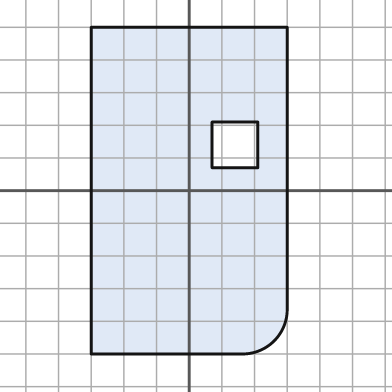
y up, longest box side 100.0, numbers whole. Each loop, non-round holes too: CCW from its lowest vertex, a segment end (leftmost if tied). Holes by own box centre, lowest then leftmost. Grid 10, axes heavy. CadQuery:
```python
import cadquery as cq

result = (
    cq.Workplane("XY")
    .moveTo(-30.0, -50.0)
    .lineTo(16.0, -50.0)
    .threePointArc((26.0, -46.0), (30.0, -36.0))
    .lineTo(30.0, 50.0)
    .lineTo(-30.0, 50.0)
    .close()
    .moveTo(7.0, 7.0)
    .lineTo(21.0, 7.0)
    .lineTo(21.0, 21.0)
    .lineTo(7.0, 21.0)
    .close()
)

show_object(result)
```